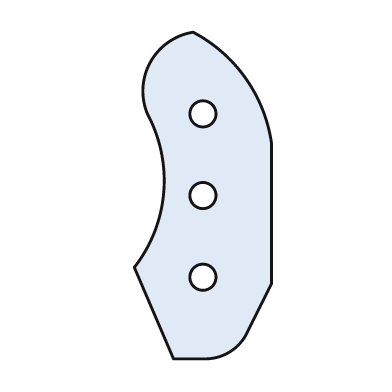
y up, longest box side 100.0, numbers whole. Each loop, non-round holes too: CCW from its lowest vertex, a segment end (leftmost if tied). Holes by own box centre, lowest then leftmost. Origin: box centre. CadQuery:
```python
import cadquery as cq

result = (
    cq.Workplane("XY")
    .moveTo(-9.0, -50.0)
    .lineTo(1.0, -50.0)
    .threePointArc((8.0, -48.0), (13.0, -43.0))
    .lineTo(21.0, -27.0)
    .lineTo(21.0, 16.0)
    .threePointArc((13.0, 36.0), (-3.0, 50.0))
    .threePointArc((-16.0, 41.0), (-17.0, 25.0))
    .threePointArc((-12.0, 1.0), (-21.0, -22.0))
    .close()
    .moveTo(0.0, -25.0)
    .circle(4.0)
    .moveTo(0.0, 0.0)
    .circle(4.0)
    .moveTo(0.0, 25.0)
    .circle(4.0)
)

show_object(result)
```